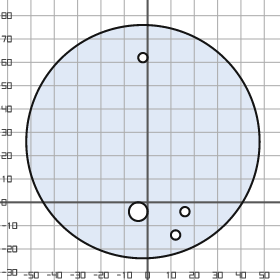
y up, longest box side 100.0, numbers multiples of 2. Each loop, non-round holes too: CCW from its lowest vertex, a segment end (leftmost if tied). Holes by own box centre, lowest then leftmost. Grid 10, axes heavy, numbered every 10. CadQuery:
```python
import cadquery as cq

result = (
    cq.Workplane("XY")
    .moveTo(-2.0, 26.0)
    .circle(50.0)
    .moveTo(12.0, -14.0)
    .circle(2.0)
    .moveTo(-4.0, -4.0)
    .circle(4.0)
    .moveTo(16.0, -4.0)
    .circle(2.0)
    .moveTo(-2.0, 62.0)
    .circle(2.0)
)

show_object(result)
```